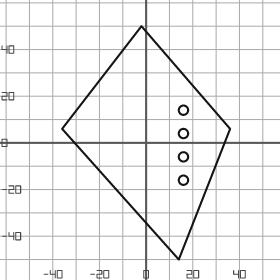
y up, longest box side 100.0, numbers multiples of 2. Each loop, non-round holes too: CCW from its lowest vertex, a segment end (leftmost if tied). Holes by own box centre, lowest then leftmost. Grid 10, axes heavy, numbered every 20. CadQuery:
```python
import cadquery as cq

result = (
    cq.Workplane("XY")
    .moveTo(14.0, -50.0)
    .lineTo(36.0, 6.0)
    .lineTo(-2.0, 50.0)
    .lineTo(-36.0, 6.0)
    .close()
    .moveTo(16.0, -16.0)
    .circle(2.0)
    .moveTo(16.0, -6.0)
    .circle(2.0)
    .moveTo(16.0, 4.0)
    .circle(2.0)
    .moveTo(16.0, 14.0)
    .circle(2.0)
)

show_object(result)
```